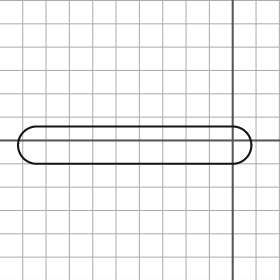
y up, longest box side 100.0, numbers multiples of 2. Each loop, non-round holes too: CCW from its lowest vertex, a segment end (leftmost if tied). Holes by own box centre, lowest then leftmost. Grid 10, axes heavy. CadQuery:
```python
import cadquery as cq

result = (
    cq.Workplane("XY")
    .moveTo(-84.0, -10.0)
    .lineTo(0.0, -10.0)
    .threePointArc((8.0, -2.0), (0.0, 6.0))
    .lineTo(-84.0, 6.0)
    .threePointArc((-92.0, -2.0), (-84.0, -10.0))
    .close()
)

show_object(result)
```